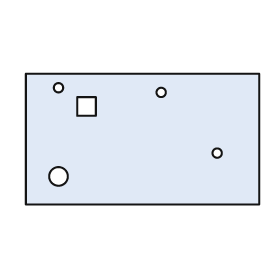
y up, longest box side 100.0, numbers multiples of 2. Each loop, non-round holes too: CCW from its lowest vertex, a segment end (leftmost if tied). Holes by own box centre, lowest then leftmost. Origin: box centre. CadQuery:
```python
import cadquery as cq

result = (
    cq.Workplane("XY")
    .moveTo(-50.0, -28.0)
    .lineTo(50.0, -28.0)
    .lineTo(50.0, 28.0)
    .lineTo(-50.0, 28.0)
    .close()
    .moveTo(-36.0, -16.0)
    .circle(4.0)
    .moveTo(32.0, -6.0)
    .circle(2.0)
    .moveTo(-28.0, 10.0)
    .lineTo(-20.0, 10.0)
    .lineTo(-20.0, 18.0)
    .lineTo(-28.0, 18.0)
    .close()
    .moveTo(8.0, 20.0)
    .circle(2.0)
    .moveTo(-36.0, 22.0)
    .circle(2.0)
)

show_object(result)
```